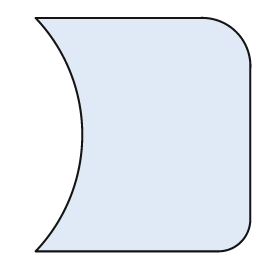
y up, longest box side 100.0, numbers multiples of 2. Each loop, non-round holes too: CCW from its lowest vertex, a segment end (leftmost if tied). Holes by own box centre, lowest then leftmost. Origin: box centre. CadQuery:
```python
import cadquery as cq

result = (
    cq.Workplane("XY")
    .moveTo(-46.0, -50.0)
    .lineTo(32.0, -50.0)
    .threePointArc((42.0, -46.0), (46.0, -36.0))
    .lineTo(46.0, 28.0)
    .threePointArc((40.0, 44.0), (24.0, 50.0))
    .lineTo(-46.0, 50.0)
    .threePointArc((-26.0, 0.0), (-46.0, -50.0))
    .close()
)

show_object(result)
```